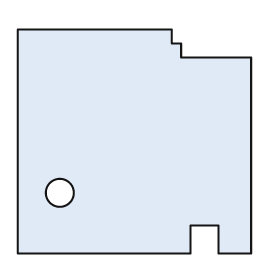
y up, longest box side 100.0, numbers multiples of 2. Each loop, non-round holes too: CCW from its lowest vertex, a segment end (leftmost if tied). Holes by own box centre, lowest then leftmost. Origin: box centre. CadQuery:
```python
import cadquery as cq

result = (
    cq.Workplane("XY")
    .moveTo(-50.0, -48.0)
    .lineTo(24.0, -48.0)
    .lineTo(24.0, -36.0)
    .lineTo(36.0, -36.0)
    .lineTo(36.0, -48.0)
    .lineTo(50.0, -48.0)
    .lineTo(50.0, 36.0)
    .lineTo(20.0, 36.0)
    .lineTo(20.0, 42.0)
    .lineTo(16.0, 42.0)
    .lineTo(16.0, 48.0)
    .lineTo(-50.0, 48.0)
    .close()
    .moveTo(-32.0, -22.0)
    .circle(6.0)
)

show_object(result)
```